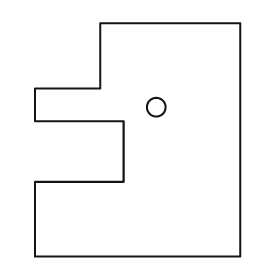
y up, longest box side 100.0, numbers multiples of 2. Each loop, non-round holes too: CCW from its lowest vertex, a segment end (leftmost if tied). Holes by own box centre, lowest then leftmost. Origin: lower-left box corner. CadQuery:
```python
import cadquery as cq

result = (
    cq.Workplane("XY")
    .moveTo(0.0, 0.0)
    .lineTo(88.0, 0.0)
    .lineTo(88.0, 100.0)
    .lineTo(28.0, 100.0)
    .lineTo(28.0, 72.0)
    .lineTo(0.0, 72.0)
    .lineTo(0.0, 58.0)
    .lineTo(38.0, 58.0)
    .lineTo(38.0, 32.0)
    .lineTo(0.0, 32.0)
    .close()
    .moveTo(52.0, 64.0)
    .circle(4.0)
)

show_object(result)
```